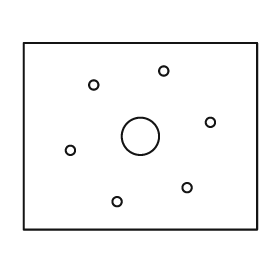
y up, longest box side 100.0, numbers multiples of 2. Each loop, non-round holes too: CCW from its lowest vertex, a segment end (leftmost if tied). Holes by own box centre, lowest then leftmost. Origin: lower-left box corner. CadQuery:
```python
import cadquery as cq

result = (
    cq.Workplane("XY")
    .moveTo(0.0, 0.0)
    .lineTo(100.0, 0.0)
    .lineTo(100.0, 80.0)
    .lineTo(0.0, 80.0)
    .close()
    .moveTo(40.0, 12.0)
    .circle(2.0)
    .moveTo(70.0, 18.0)
    .circle(2.0)
    .moveTo(20.0, 34.0)
    .circle(2.0)
    .moveTo(50.0, 40.0)
    .circle(8.0)
    .moveTo(80.0, 46.0)
    .circle(2.0)
    .moveTo(30.0, 62.0)
    .circle(2.0)
    .moveTo(60.0, 68.0)
    .circle(2.0)
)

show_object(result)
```